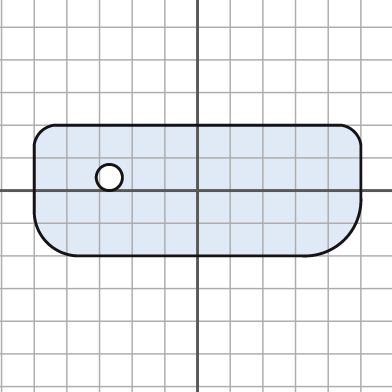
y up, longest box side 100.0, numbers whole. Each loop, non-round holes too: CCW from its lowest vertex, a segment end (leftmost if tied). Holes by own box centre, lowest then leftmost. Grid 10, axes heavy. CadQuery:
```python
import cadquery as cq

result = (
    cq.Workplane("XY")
    .moveTo(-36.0, -20.0)
    .lineTo(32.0, -20.0)
    .threePointArc((45.0, -15.0), (50.0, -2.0))
    .lineTo(50.0, 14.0)
    .threePointArc((48.0, 18.0), (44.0, 20.0))
    .lineTo(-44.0, 20.0)
    .threePointArc((-48.0, 18.0), (-50.0, 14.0))
    .lineTo(-50.0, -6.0)
    .threePointArc((-46.0, -16.0), (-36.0, -20.0))
    .close()
    .moveTo(-27.0, 4.0)
    .circle(4.0)
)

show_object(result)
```